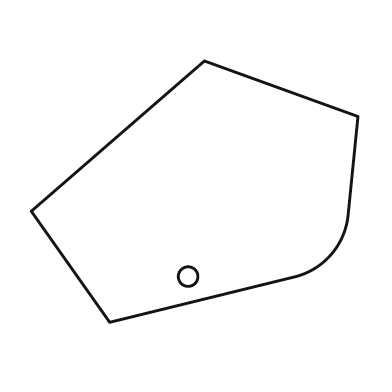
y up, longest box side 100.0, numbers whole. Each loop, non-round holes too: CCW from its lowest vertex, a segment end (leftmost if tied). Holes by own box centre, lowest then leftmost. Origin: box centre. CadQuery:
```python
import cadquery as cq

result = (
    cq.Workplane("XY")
    .moveTo(-26.0, -40.0)
    .lineTo(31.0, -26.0)
    .threePointArc((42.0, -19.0), (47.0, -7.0))
    .lineTo(50.0, 23.0)
    .lineTo(3.0, 40.0)
    .lineTo(-50.0, -6.0)
    .close()
    .moveTo(-2.0, -26.0)
    .circle(3.0)
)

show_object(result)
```